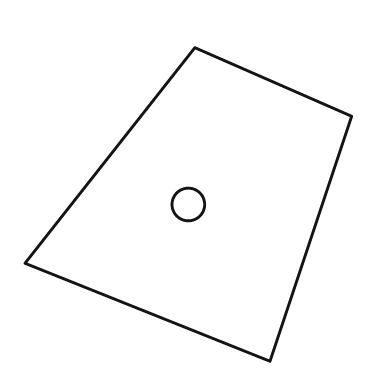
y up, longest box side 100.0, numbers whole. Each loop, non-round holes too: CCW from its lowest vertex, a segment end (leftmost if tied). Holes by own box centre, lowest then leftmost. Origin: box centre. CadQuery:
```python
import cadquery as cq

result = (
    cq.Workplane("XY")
    .moveTo(25.0, -48.0)
    .lineTo(50.0, 27.0)
    .lineTo(2.0, 48.0)
    .lineTo(-50.0, -18.0)
    .close()
    .moveTo(0.0, 0.0)
    .circle(5.0)
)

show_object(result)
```